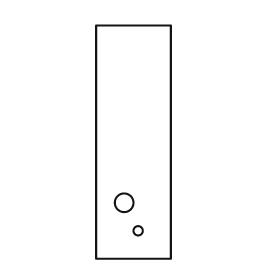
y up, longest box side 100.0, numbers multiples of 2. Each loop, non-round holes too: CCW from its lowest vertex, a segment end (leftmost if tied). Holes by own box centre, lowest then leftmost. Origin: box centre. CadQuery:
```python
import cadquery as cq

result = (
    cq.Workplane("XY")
    .moveTo(-16.0, -50.0)
    .lineTo(16.0, -50.0)
    .lineTo(16.0, 50.0)
    .lineTo(-16.0, 50.0)
    .close()
    .moveTo(2.0, -38.0)
    .circle(2.0)
    .moveTo(-4.0, -26.0)
    .circle(4.0)
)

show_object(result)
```